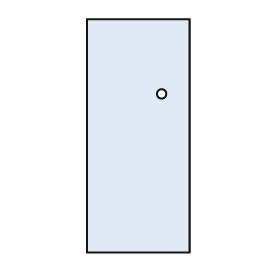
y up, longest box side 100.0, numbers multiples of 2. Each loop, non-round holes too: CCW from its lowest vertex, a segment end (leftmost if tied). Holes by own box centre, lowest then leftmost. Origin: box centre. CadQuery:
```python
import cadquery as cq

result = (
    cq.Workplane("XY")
    .moveTo(-22.0, -50.0)
    .lineTo(22.0, -50.0)
    .lineTo(22.0, 50.0)
    .lineTo(-22.0, 50.0)
    .close()
    .moveTo(10.0, 18.0)
    .circle(2.0)
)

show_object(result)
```